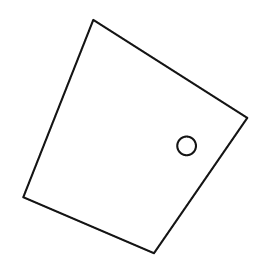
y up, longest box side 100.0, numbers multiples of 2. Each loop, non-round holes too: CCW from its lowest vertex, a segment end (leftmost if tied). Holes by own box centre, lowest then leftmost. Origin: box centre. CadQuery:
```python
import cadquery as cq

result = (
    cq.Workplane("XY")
    .moveTo(8.0, -50.0)
    .lineTo(48.0, 8.0)
    .lineTo(-18.0, 50.0)
    .lineTo(-48.0, -26.0)
    .close()
    .moveTo(22.0, -4.0)
    .circle(4.0)
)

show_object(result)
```